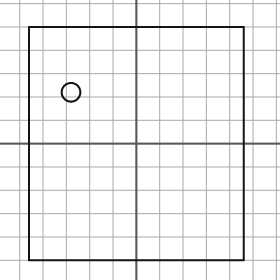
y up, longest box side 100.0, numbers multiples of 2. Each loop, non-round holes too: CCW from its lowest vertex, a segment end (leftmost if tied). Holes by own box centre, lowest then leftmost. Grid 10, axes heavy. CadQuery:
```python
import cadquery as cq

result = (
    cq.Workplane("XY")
    .moveTo(-46.0, -50.0)
    .lineTo(46.0, -50.0)
    .lineTo(46.0, 50.0)
    .lineTo(-46.0, 50.0)
    .close()
    .moveTo(-28.0, 22.0)
    .circle(4.0)
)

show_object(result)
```